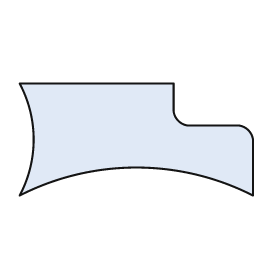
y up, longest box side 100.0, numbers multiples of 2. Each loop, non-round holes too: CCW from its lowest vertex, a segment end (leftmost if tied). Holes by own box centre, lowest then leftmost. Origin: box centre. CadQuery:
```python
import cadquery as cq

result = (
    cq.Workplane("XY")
    .moveTo(-50.0, -24.0)
    .threePointArc((0.0, -12.0), (50.0, -24.0))
    .lineTo(50.0, 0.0)
    .threePointArc((48.0, 4.0), (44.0, 6.0))
    .lineTo(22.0, 6.0)
    .threePointArc((18.0, 8.0), (16.0, 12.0))
    .lineTo(16.0, 24.0)
    .lineTo(-50.0, 24.0)
    .threePointArc((-44.0, 0.0), (-50.0, -24.0))
    .close()
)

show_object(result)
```